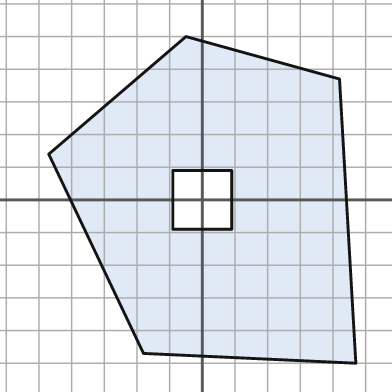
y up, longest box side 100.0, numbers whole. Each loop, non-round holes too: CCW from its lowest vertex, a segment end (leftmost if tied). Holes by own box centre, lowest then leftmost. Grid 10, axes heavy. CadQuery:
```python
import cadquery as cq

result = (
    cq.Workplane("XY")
    .moveTo(47.0, -50.0)
    .lineTo(42.0, 37.0)
    .lineTo(-5.0, 50.0)
    .lineTo(-47.0, 14.0)
    .lineTo(-18.0, -47.0)
    .close()
    .moveTo(-9.0, -9.0)
    .lineTo(9.0, -9.0)
    .lineTo(9.0, 9.0)
    .lineTo(-9.0, 9.0)
    .close()
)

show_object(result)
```